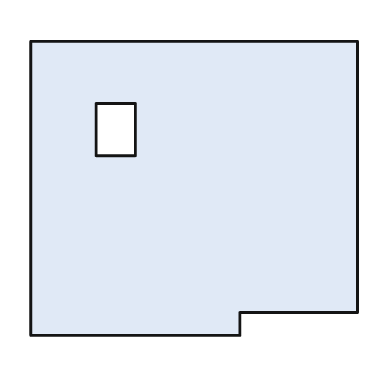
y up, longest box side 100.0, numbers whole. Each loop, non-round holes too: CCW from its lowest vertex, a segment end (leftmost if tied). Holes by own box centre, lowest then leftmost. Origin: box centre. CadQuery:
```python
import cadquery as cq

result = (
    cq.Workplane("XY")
    .moveTo(-50.0, -45.0)
    .lineTo(14.0, -45.0)
    .lineTo(14.0, -38.0)
    .lineTo(50.0, -38.0)
    .lineTo(50.0, 45.0)
    .lineTo(-50.0, 45.0)
    .close()
    .moveTo(-30.0, 10.0)
    .lineTo(-18.0, 10.0)
    .lineTo(-18.0, 26.0)
    .lineTo(-30.0, 26.0)
    .close()
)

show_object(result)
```